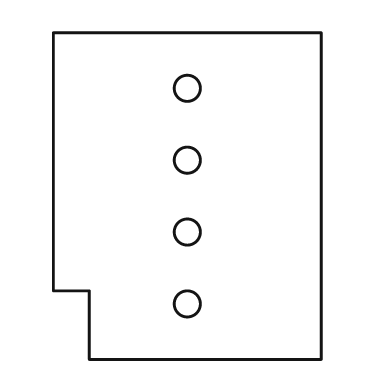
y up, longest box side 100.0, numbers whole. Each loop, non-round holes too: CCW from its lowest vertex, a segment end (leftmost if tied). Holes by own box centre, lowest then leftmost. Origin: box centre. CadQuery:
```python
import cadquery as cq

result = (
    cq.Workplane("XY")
    .moveTo(-30.0, -50.0)
    .lineTo(41.0, -50.0)
    .lineTo(41.0, 50.0)
    .lineTo(-41.0, 50.0)
    .lineTo(-41.0, -29.0)
    .lineTo(-30.0, -29.0)
    .close()
    .moveTo(0.0, -33.0)
    .circle(4.0)
    .moveTo(0.0, -11.0)
    .circle(4.0)
    .moveTo(0.0, 11.0)
    .circle(4.0)
    .moveTo(0.0, 33.0)
    .circle(4.0)
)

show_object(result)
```